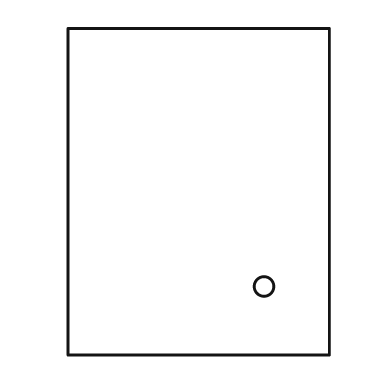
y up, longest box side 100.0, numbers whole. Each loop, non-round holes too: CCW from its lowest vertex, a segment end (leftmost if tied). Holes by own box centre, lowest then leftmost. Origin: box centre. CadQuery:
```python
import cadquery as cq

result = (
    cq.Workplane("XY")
    .moveTo(-40.0, -50.0)
    .lineTo(40.0, -50.0)
    .lineTo(40.0, 50.0)
    .lineTo(-40.0, 50.0)
    .close()
    .moveTo(20.0, -29.0)
    .circle(3.0)
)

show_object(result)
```